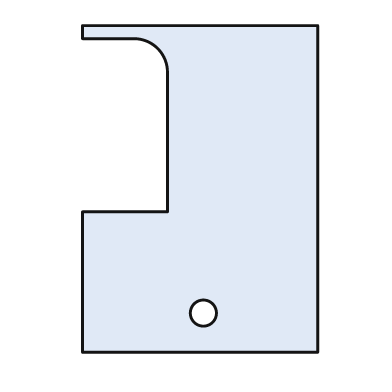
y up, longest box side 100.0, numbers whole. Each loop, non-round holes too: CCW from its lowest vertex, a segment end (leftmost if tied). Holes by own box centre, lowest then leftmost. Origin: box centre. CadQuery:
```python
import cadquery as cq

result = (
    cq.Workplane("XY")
    .moveTo(-36.0, -50.0)
    .lineTo(36.0, -50.0)
    .lineTo(36.0, 50.0)
    .lineTo(-36.0, 50.0)
    .lineTo(-36.0, 46.0)
    .lineTo(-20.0, 46.0)
    .threePointArc((-13.0, 43.0), (-10.0, 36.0))
    .lineTo(-10.0, -7.0)
    .lineTo(-36.0, -7.0)
    .close()
    .moveTo(1.0, -38.0)
    .circle(4.0)
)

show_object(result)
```